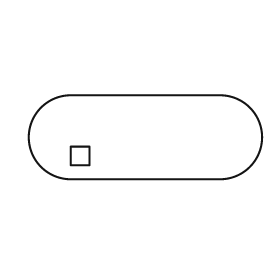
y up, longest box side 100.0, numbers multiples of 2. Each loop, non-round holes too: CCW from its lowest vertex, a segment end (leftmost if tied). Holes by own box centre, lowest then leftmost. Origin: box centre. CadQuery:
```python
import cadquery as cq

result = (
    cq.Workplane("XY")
    .moveTo(-32.0, -18.0)
    .lineTo(32.0, -18.0)
    .threePointArc((50.0, 0.0), (32.0, 18.0))
    .lineTo(-32.0, 18.0)
    .threePointArc((-50.0, 0.0), (-32.0, -18.0))
    .close()
    .moveTo(-32.0, -12.0)
    .lineTo(-24.0, -12.0)
    .lineTo(-24.0, -4.0)
    .lineTo(-32.0, -4.0)
    .close()
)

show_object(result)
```